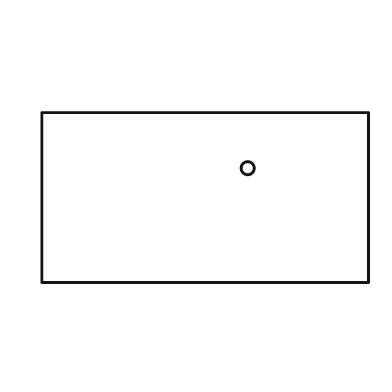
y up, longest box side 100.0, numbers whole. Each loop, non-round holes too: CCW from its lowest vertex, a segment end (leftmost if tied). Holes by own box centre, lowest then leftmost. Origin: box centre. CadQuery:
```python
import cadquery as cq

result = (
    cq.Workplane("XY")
    .moveTo(-50.0, -26.0)
    .lineTo(50.0, -26.0)
    .lineTo(50.0, 26.0)
    .lineTo(-50.0, 26.0)
    .close()
    .moveTo(13.0, 9.0)
    .circle(2.0)
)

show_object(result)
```